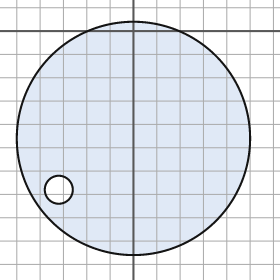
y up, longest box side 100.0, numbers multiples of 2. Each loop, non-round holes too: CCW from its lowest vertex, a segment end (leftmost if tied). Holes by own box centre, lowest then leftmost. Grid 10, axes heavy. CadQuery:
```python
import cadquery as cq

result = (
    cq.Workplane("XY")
    .moveTo(0.0, -46.0)
    .circle(50.0)
    .moveTo(-32.0, -68.0)
    .circle(6.0)
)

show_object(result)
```